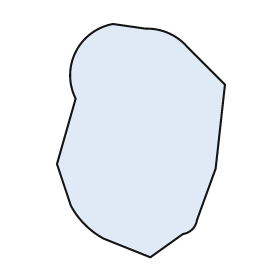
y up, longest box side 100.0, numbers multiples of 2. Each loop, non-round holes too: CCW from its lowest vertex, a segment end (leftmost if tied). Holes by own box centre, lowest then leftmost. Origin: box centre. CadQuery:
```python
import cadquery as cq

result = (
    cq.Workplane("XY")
    .moveTo(4.0, -50.0)
    .lineTo(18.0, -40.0)
    .threePointArc((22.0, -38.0), (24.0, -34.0))
    .lineTo(32.0, -12.0)
    .lineTo(36.0, 24.0)
    .lineTo(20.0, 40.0)
    .threePointArc((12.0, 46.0), (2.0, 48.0))
    .lineTo(-12.0, 50.0)
    .threePointArc((-28.0, 38.0), (-28.0, 18.0))
    .lineTo(-36.0, -10.0)
    .lineTo(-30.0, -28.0)
    .threePointArc((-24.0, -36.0), (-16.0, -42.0))
    .close()
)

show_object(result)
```